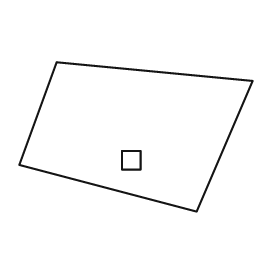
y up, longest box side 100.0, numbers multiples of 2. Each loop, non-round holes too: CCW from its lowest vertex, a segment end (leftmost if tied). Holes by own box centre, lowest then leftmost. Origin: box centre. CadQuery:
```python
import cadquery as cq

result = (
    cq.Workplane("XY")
    .moveTo(26.0, -32.0)
    .lineTo(50.0, 24.0)
    .lineTo(-34.0, 32.0)
    .lineTo(-50.0, -12.0)
    .close()
    .moveTo(-6.0, -14.0)
    .lineTo(2.0, -14.0)
    .lineTo(2.0, -6.0)
    .lineTo(-6.0, -6.0)
    .close()
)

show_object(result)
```